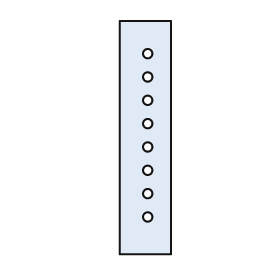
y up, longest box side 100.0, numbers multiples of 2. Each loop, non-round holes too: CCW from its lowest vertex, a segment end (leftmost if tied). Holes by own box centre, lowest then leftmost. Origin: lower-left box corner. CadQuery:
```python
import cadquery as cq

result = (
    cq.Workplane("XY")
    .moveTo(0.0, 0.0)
    .lineTo(22.0, 0.0)
    .lineTo(22.0, 100.0)
    .lineTo(0.0, 100.0)
    .close()
    .moveTo(12.0, 16.0)
    .circle(2.0)
    .moveTo(12.0, 26.0)
    .circle(2.0)
    .moveTo(12.0, 36.0)
    .circle(2.0)
    .moveTo(12.0, 46.0)
    .circle(2.0)
    .moveTo(12.0, 56.0)
    .circle(2.0)
    .moveTo(12.0, 66.0)
    .circle(2.0)
    .moveTo(12.0, 76.0)
    .circle(2.0)
    .moveTo(12.0, 86.0)
    .circle(2.0)
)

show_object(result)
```